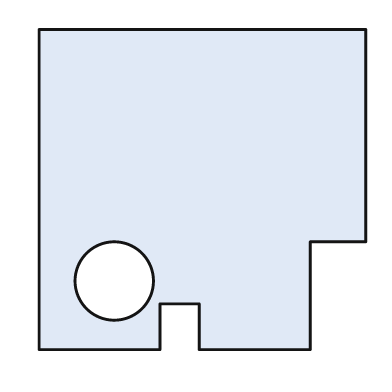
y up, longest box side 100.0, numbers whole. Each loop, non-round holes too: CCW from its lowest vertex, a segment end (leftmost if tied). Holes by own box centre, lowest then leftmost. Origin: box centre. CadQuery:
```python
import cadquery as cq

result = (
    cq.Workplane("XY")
    .moveTo(-50.0, -49.0)
    .lineTo(-13.0, -49.0)
    .lineTo(-13.0, -35.0)
    .lineTo(-1.0, -35.0)
    .lineTo(-1.0, -49.0)
    .lineTo(33.0, -49.0)
    .lineTo(33.0, -16.0)
    .lineTo(50.0, -16.0)
    .lineTo(50.0, 49.0)
    .lineTo(-50.0, 49.0)
    .close()
    .moveTo(-27.0, -28.0)
    .circle(12.0)
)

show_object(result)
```